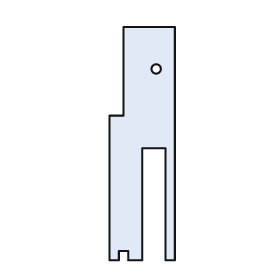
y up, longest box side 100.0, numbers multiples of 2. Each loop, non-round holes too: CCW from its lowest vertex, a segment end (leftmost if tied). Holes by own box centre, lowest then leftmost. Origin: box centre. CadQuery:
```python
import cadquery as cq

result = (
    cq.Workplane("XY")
    .moveTo(-14.0, -50.0)
    .lineTo(-10.0, -50.0)
    .lineTo(-10.0, -46.0)
    .lineTo(-6.0, -46.0)
    .lineTo(-6.0, -50.0)
    .lineTo(0.0, -50.0)
    .lineTo(0.0, -2.0)
    .lineTo(10.0, -2.0)
    .lineTo(10.0, -50.0)
    .lineTo(14.0, -50.0)
    .lineTo(14.0, 50.0)
    .lineTo(-8.0, 50.0)
    .lineTo(-8.0, 12.0)
    .lineTo(-14.0, 12.0)
    .close()
    .moveTo(6.0, 32.0)
    .circle(2.0)
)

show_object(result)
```